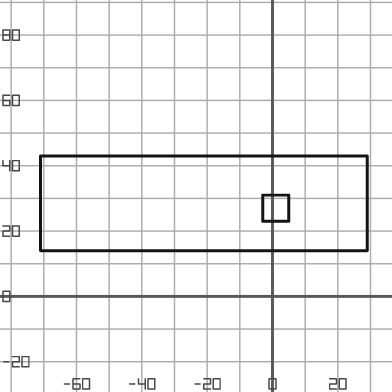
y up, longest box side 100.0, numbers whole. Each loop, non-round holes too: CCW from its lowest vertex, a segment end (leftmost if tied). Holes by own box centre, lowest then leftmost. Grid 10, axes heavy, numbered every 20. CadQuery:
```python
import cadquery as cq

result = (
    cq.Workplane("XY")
    .moveTo(-71.0, 14.0)
    .lineTo(29.0, 14.0)
    .lineTo(29.0, 43.0)
    .lineTo(-71.0, 43.0)
    .close()
    .moveTo(-3.0, 23.0)
    .lineTo(5.0, 23.0)
    .lineTo(5.0, 31.0)
    .lineTo(-3.0, 31.0)
    .close()
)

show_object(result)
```